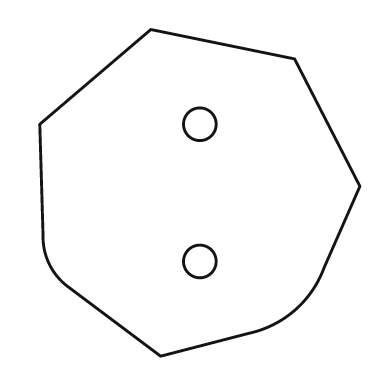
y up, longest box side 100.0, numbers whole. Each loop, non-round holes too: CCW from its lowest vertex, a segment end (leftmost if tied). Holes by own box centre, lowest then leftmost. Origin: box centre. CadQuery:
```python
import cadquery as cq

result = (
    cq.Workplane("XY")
    .moveTo(-12.0, -50.0)
    .lineTo(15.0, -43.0)
    .threePointArc((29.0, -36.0), (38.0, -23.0))
    .lineTo(49.0, 2.0)
    .lineTo(29.0, 41.0)
    .lineTo(-15.0, 50.0)
    .lineTo(-49.0, 21.0)
    .lineTo(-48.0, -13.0)
    .threePointArc((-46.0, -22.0), (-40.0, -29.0))
    .close()
    .moveTo(0.0, -21.0)
    .circle(5.0)
    .moveTo(0.0, 21.0)
    .circle(5.0)
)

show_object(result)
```